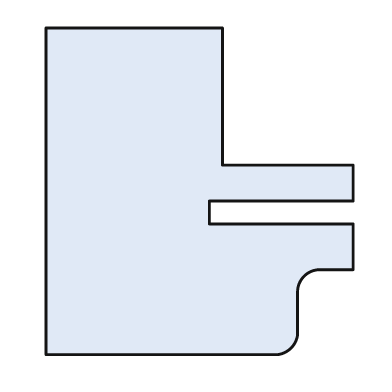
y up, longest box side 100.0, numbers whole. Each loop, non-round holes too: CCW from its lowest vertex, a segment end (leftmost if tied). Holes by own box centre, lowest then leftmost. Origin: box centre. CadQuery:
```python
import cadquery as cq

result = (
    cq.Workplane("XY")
    .moveTo(-47.0, -50.0)
    .lineTo(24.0, -50.0)
    .threePointArc((28.0, -48.0), (30.0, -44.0))
    .lineTo(30.0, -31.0)
    .threePointArc((32.0, -26.0), (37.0, -24.0))
    .lineTo(47.0, -24.0)
    .lineTo(47.0, -10.0)
    .lineTo(3.0, -10.0)
    .lineTo(3.0, -3.0)
    .lineTo(47.0, -3.0)
    .lineTo(47.0, 8.0)
    .lineTo(7.0, 8.0)
    .lineTo(7.0, 50.0)
    .lineTo(-47.0, 50.0)
    .close()
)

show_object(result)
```